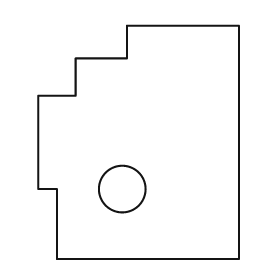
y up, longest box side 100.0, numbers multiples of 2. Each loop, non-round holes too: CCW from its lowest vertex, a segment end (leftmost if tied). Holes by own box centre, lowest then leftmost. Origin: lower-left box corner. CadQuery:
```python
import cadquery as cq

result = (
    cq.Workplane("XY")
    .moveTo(8.0, 0.0)
    .lineTo(86.0, 0.0)
    .lineTo(86.0, 100.0)
    .lineTo(38.0, 100.0)
    .lineTo(38.0, 86.0)
    .lineTo(16.0, 86.0)
    .lineTo(16.0, 70.0)
    .lineTo(0.0, 70.0)
    .lineTo(0.0, 30.0)
    .lineTo(8.0, 30.0)
    .close()
    .moveTo(36.0, 30.0)
    .circle(10.0)
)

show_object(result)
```